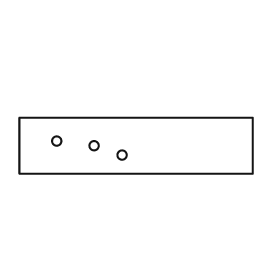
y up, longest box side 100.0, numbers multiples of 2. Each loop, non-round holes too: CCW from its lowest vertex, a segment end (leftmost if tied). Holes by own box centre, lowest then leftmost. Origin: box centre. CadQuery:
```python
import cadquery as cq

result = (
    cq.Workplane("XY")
    .moveTo(-50.0, -12.0)
    .lineTo(50.0, -12.0)
    .lineTo(50.0, 12.0)
    .lineTo(-50.0, 12.0)
    .close()
    .moveTo(-6.0, -4.0)
    .circle(2.0)
    .moveTo(-18.0, 0.0)
    .circle(2.0)
    .moveTo(-34.0, 2.0)
    .circle(2.0)
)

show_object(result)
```